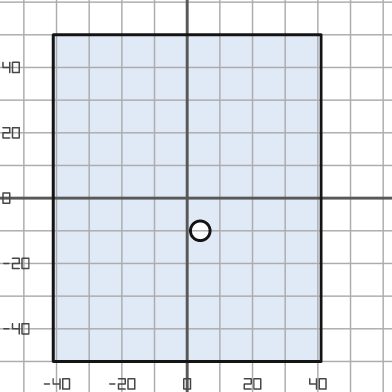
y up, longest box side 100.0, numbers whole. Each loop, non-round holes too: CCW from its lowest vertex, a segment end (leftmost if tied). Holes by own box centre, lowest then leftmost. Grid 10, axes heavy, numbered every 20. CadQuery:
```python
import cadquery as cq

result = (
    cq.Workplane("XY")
    .moveTo(-41.0, -50.0)
    .lineTo(41.0, -50.0)
    .lineTo(41.0, 50.0)
    .lineTo(-41.0, 50.0)
    .close()
    .moveTo(4.0, -10.0)
    .circle(3.0)
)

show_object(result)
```